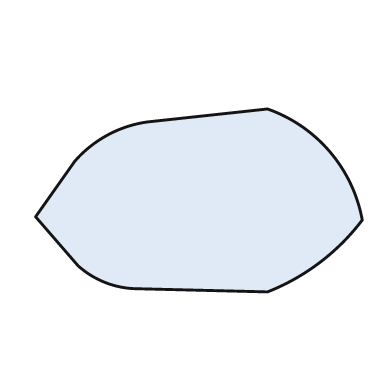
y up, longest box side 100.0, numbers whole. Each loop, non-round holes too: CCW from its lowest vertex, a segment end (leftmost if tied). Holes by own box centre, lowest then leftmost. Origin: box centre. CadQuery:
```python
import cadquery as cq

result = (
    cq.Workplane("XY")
    .moveTo(21.0, -28.0)
    .threePointArc((37.0, -19.0), (50.0, -6.0))
    .threePointArc((40.0, 15.0), (21.0, 28.0))
    .lineTo(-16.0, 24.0)
    .threePointArc((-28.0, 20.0), (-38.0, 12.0))
    .lineTo(-50.0, -5.0)
    .lineTo(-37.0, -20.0)
    .threePointArc((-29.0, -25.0), (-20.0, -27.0))
    .close()
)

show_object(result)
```